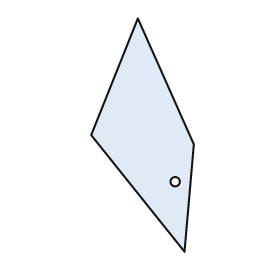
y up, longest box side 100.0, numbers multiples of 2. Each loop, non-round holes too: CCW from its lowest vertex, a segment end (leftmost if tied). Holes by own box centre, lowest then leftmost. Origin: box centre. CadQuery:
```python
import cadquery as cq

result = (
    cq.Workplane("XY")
    .moveTo(18.0, -50.0)
    .lineTo(22.0, -4.0)
    .lineTo(-2.0, 50.0)
    .lineTo(-22.0, 0.0)
    .close()
    .moveTo(14.0, -20.0)
    .circle(2.0)
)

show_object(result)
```